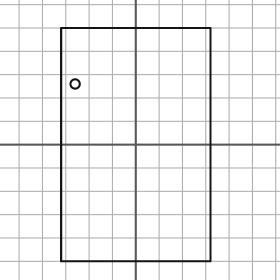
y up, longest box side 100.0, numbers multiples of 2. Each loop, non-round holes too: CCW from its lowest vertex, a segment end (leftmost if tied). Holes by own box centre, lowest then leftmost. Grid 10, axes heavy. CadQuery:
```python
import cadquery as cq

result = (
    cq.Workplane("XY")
    .moveTo(-32.0, -50.0)
    .lineTo(32.0, -50.0)
    .lineTo(32.0, 50.0)
    .lineTo(-32.0, 50.0)
    .close()
    .moveTo(-26.0, 26.0)
    .circle(2.0)
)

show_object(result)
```